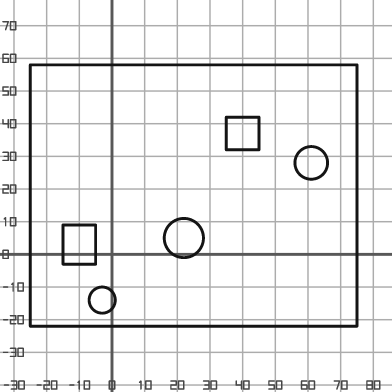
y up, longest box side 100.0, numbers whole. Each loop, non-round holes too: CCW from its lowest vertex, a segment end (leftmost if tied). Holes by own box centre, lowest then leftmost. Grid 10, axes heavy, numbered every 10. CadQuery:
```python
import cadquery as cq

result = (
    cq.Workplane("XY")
    .moveTo(-25.0, -22.0)
    .lineTo(75.0, -22.0)
    .lineTo(75.0, 58.0)
    .lineTo(-25.0, 58.0)
    .close()
    .moveTo(-3.0, -14.0)
    .circle(4.0)
    .moveTo(-15.0, -3.0)
    .lineTo(-5.0, -3.0)
    .lineTo(-5.0, 9.0)
    .lineTo(-15.0, 9.0)
    .close()
    .moveTo(22.0, 5.0)
    .circle(6.0)
    .moveTo(61.0, 28.0)
    .circle(5.0)
    .moveTo(35.0, 32.0)
    .lineTo(45.0, 32.0)
    .lineTo(45.0, 42.0)
    .lineTo(35.0, 42.0)
    .close()
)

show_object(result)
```